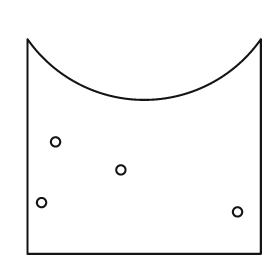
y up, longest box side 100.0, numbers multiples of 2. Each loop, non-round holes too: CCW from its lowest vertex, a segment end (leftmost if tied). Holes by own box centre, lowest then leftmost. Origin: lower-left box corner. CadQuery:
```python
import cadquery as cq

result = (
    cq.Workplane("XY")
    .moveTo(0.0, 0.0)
    .lineTo(100.0, 0.0)
    .lineTo(100.0, 92.0)
    .threePointArc((50.0, 66.0), (0.0, 92.0))
    .close()
    .moveTo(90.0, 18.0)
    .circle(2.0)
    .moveTo(6.0, 22.0)
    .circle(2.0)
    .moveTo(40.0, 36.0)
    .circle(2.0)
    .moveTo(12.0, 48.0)
    .circle(2.0)
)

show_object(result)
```